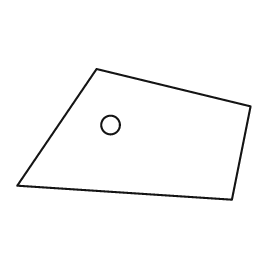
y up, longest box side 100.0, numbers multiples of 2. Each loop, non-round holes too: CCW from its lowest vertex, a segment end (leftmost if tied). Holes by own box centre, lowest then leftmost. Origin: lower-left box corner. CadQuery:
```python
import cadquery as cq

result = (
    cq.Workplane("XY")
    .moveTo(92.0, 0.0)
    .lineTo(100.0, 40.0)
    .lineTo(34.0, 56.0)
    .lineTo(0.0, 6.0)
    .close()
    .moveTo(40.0, 32.0)
    .circle(4.0)
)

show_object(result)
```